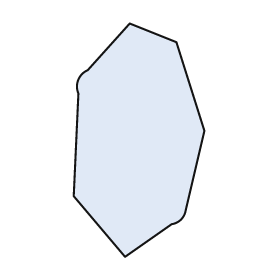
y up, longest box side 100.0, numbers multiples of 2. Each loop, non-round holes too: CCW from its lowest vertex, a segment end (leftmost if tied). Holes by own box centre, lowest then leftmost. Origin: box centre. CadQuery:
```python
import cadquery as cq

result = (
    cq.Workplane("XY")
    .moveTo(-6.0, -50.0)
    .lineTo(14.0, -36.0)
    .threePointArc((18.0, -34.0), (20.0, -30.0))
    .lineTo(28.0, 4.0)
    .lineTo(16.0, 42.0)
    .lineTo(-4.0, 50.0)
    .lineTo(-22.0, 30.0)
    .threePointArc((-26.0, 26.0), (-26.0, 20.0))
    .lineTo(-28.0, -24.0)
    .close()
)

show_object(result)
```